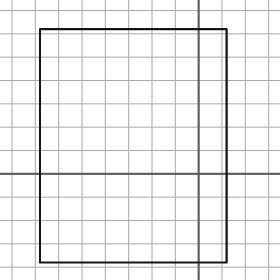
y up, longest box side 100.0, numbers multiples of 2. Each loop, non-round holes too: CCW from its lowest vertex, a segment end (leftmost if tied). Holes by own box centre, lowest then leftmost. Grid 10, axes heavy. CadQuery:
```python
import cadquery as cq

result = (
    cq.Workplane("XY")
    .moveTo(-68.0, -38.0)
    .lineTo(12.0, -38.0)
    .lineTo(12.0, 62.0)
    .lineTo(-68.0, 62.0)
    .close()
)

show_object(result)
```